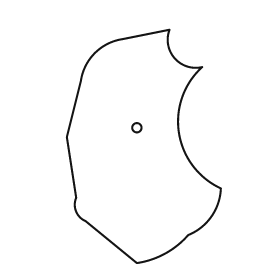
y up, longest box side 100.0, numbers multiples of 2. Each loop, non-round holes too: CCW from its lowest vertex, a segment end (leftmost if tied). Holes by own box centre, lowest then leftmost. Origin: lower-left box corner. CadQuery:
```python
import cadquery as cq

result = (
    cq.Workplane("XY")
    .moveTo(30.0, 0.0)
    .threePointArc((42.0, 4.0), (52.0, 12.0))
    .threePointArc((62.0, 20.0), (66.0, 32.0))
    .threePointArc((48.0, 56.0), (58.0, 84.0))
    .threePointArc((46.0, 88.0), (44.0, 100.0))
    .lineTo(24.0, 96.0)
    .threePointArc((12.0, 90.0), (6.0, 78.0))
    .lineTo(0.0, 54.0)
    .lineTo(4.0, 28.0)
    .threePointArc((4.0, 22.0), (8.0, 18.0))
    .close()
    .moveTo(30.0, 58.0)
    .circle(2.0)
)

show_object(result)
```